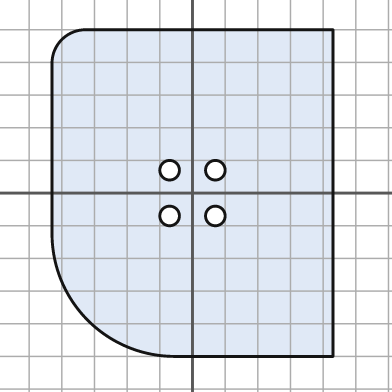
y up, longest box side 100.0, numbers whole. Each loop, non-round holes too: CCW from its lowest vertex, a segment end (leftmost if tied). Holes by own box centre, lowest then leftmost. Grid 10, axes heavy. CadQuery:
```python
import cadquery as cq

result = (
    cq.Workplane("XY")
    .moveTo(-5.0, -50.0)
    .lineTo(43.0, -50.0)
    .lineTo(43.0, 50.0)
    .lineTo(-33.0, 50.0)
    .threePointArc((-40.0, 47.0), (-43.0, 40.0))
    .lineTo(-43.0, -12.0)
    .threePointArc((-32.0, -39.0), (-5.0, -50.0))
    .close()
    .moveTo(-7.0, -7.0)
    .circle(3.0)
    .moveTo(7.0, -7.0)
    .circle(3.0)
    .moveTo(-7.0, 7.0)
    .circle(3.0)
    .moveTo(7.0, 7.0)
    .circle(3.0)
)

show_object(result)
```